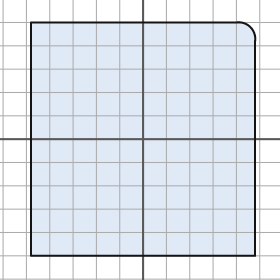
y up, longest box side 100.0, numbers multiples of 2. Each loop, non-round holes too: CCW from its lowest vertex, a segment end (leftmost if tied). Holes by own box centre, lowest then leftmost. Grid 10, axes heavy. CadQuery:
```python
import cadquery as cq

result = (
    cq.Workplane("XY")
    .moveTo(-48.0, -50.0)
    .lineTo(48.0, -50.0)
    .lineTo(48.0, 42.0)
    .threePointArc((46.0, 48.0), (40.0, 50.0))
    .lineTo(-48.0, 50.0)
    .close()
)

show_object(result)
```